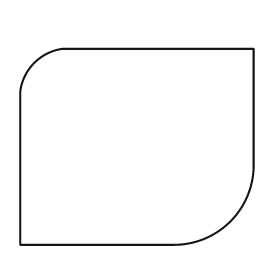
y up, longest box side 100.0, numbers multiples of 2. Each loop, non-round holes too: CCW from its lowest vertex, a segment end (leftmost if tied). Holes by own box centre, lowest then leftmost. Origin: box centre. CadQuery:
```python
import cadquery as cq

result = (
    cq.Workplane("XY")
    .moveTo(-50.0, -42.0)
    .lineTo(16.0, -42.0)
    .threePointArc((40.0, -32.0), (50.0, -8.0))
    .lineTo(50.0, 42.0)
    .lineTo(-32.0, 42.0)
    .threePointArc((-44.0, 36.0), (-50.0, 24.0))
    .close()
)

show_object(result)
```